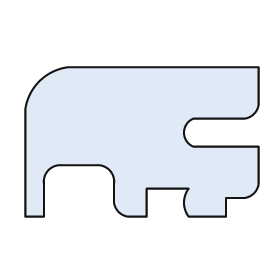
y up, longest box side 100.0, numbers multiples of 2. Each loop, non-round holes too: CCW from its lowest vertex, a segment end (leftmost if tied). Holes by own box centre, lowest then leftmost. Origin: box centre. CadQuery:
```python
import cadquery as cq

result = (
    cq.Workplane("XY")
    .moveTo(-50.0, -32.0)
    .lineTo(-42.0, -32.0)
    .lineTo(-42.0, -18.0)
    .threePointArc((-40.0, -12.0), (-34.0, -10.0))
    .lineTo(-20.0, -10.0)
    .threePointArc((-14.0, -12.0), (-12.0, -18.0))
    .lineTo(-12.0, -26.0)
    .threePointArc((-10.0, -30.0), (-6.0, -32.0))
    .lineTo(2.0, -32.0)
    .lineTo(2.0, -20.0)
    .lineTo(20.0, -20.0)
    .threePointArc((18.0, -26.0), (20.0, -32.0))
    .lineTo(36.0, -32.0)
    .lineTo(36.0, -24.0)
    .lineTo(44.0, -24.0)
    .threePointArc((48.0, -22.0), (50.0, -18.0))
    .lineTo(50.0, -2.0)
    .lineTo(22.0, -2.0)
    .threePointArc((18.0, 4.0), (22.0, 10.0))
    .lineTo(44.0, 10.0)
    .threePointArc((48.0, 12.0), (50.0, 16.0))
    .lineTo(50.0, 32.0)
    .lineTo(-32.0, 32.0)
    .threePointArc((-44.0, 26.0), (-50.0, 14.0))
    .close()
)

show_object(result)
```